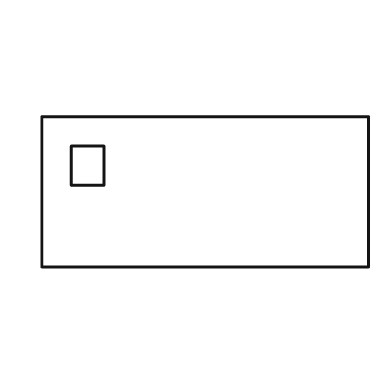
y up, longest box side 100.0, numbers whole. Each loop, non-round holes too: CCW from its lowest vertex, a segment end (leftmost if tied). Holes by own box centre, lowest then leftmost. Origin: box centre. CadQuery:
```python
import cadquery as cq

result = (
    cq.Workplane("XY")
    .moveTo(-50.0, -23.0)
    .lineTo(50.0, -23.0)
    .lineTo(50.0, 23.0)
    .lineTo(-50.0, 23.0)
    .close()
    .moveTo(-41.0, 2.0)
    .lineTo(-31.0, 2.0)
    .lineTo(-31.0, 14.0)
    .lineTo(-41.0, 14.0)
    .close()
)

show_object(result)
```